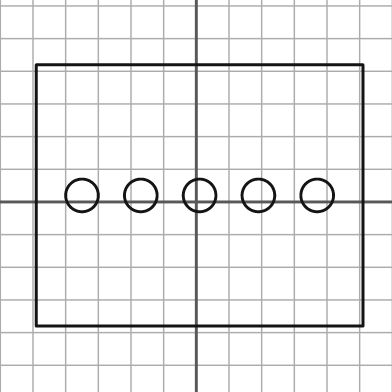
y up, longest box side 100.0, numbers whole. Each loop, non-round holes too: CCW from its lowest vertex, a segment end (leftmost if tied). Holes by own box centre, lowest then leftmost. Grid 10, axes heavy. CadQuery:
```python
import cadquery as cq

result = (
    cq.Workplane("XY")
    .moveTo(-49.0, -38.0)
    .lineTo(51.0, -38.0)
    .lineTo(51.0, 42.0)
    .lineTo(-49.0, 42.0)
    .close()
    .moveTo(-35.0, 2.0)
    .circle(5.0)
    .moveTo(-17.0, 2.0)
    .circle(5.0)
    .moveTo(1.0, 2.0)
    .circle(5.0)
    .moveTo(19.0, 2.0)
    .circle(5.0)
    .moveTo(37.0, 2.0)
    .circle(5.0)
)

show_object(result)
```